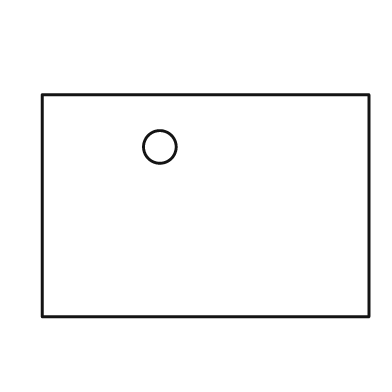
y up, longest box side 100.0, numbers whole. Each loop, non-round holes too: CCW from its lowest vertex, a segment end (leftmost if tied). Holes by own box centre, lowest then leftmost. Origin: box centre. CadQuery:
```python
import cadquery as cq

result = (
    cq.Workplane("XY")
    .moveTo(-50.0, -34.0)
    .lineTo(50.0, -34.0)
    .lineTo(50.0, 34.0)
    .lineTo(-50.0, 34.0)
    .close()
    .moveTo(-14.0, 18.0)
    .circle(5.0)
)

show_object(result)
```